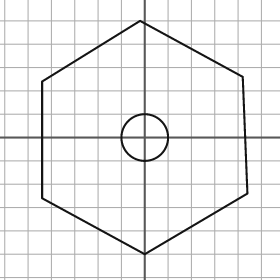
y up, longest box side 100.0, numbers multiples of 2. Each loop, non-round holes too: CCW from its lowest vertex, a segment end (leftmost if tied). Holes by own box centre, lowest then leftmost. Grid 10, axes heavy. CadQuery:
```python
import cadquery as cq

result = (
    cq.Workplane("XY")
    .moveTo(0.0, -50.0)
    .lineTo(44.0, -24.0)
    .lineTo(42.0, 26.0)
    .lineTo(-2.0, 50.0)
    .lineTo(-44.0, 24.0)
    .lineTo(-44.0, -26.0)
    .close()
    .moveTo(0.0, 0.0)
    .circle(10.0)
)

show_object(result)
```